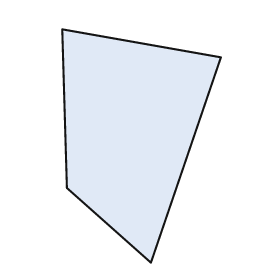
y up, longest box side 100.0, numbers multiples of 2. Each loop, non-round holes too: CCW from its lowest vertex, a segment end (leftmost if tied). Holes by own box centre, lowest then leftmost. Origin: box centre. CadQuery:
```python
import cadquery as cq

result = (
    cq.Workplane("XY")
    .moveTo(4.0, -50.0)
    .lineTo(34.0, 38.0)
    .lineTo(-34.0, 50.0)
    .lineTo(-32.0, -18.0)
    .close()
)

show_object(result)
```